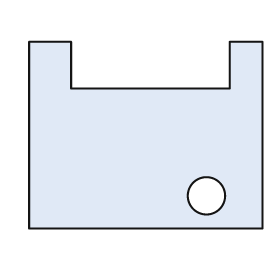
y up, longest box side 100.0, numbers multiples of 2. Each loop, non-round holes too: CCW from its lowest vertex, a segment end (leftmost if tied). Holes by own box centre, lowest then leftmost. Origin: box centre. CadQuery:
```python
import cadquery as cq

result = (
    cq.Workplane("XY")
    .moveTo(-50.0, -40.0)
    .lineTo(50.0, -40.0)
    .lineTo(50.0, 40.0)
    .lineTo(36.0, 40.0)
    .lineTo(36.0, 20.0)
    .lineTo(-32.0, 20.0)
    .lineTo(-32.0, 40.0)
    .lineTo(-50.0, 40.0)
    .close()
    .moveTo(26.0, -26.0)
    .circle(8.0)
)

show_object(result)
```